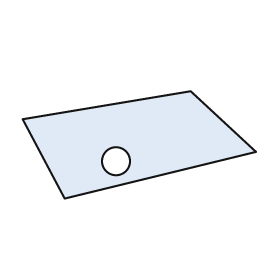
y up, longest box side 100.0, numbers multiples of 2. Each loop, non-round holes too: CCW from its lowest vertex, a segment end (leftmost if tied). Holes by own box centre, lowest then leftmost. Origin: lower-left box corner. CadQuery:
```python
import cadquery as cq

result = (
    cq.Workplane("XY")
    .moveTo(18.0, 0.0)
    .lineTo(100.0, 20.0)
    .lineTo(72.0, 46.0)
    .lineTo(0.0, 34.0)
    .close()
    .moveTo(40.0, 16.0)
    .circle(6.0)
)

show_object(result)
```